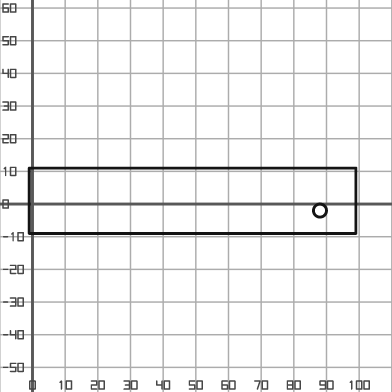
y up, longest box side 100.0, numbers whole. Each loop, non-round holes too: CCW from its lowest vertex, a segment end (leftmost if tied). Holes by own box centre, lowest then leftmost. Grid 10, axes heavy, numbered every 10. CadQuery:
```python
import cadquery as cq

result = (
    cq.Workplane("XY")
    .moveTo(-1.0, -9.0)
    .lineTo(99.0, -9.0)
    .lineTo(99.0, 11.0)
    .lineTo(-1.0, 11.0)
    .close()
    .moveTo(88.0, -2.0)
    .circle(2.0)
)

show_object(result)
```